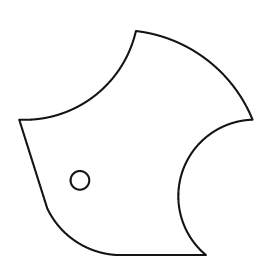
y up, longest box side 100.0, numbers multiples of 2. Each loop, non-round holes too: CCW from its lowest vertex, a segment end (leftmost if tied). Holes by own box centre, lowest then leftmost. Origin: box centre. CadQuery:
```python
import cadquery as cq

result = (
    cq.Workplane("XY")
    .moveTo(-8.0, -48.0)
    .lineTo(30.0, -48.0)
    .threePointArc((20.0, -12.0), (50.0, 10.0))
    .threePointArc((30.0, 36.0), (0.0, 48.0))
    .threePointArc((-18.0, 20.0), (-50.0, 10.0))
    .lineTo(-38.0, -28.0)
    .threePointArc((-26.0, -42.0), (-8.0, -48.0))
    .close()
    .moveTo(-24.0, -16.0)
    .circle(4.0)
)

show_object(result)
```